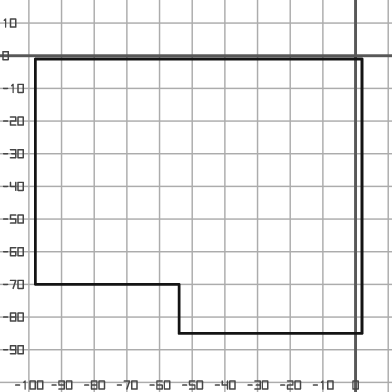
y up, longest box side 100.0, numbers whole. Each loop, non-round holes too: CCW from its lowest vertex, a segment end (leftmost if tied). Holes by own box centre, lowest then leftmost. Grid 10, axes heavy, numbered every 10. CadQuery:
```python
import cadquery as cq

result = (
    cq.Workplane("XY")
    .moveTo(-54.0, -85.0)
    .lineTo(2.0, -85.0)
    .lineTo(2.0, -1.0)
    .lineTo(-98.0, -1.0)
    .lineTo(-98.0, -70.0)
    .lineTo(-54.0, -70.0)
    .close()
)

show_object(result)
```